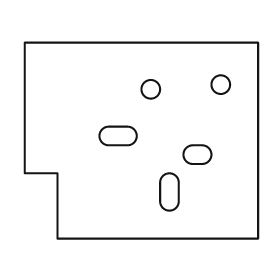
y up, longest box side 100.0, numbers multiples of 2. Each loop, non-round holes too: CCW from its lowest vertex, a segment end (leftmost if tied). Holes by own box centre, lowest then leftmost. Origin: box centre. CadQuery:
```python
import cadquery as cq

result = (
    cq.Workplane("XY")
    .moveTo(-36.0, -42.0)
    .lineTo(50.0, -42.0)
    .lineTo(50.0, 42.0)
    .lineTo(-50.0, 42.0)
    .lineTo(-50.0, -14.0)
    .lineTo(-36.0, -14.0)
    .close()
    .moveTo(8.0, -26.0)
    .threePointArc((12.0, -30.0), (16.0, -26.0))
    .lineTo(16.0, -18.0)
    .threePointArc((12.0, -14.0), (8.0, -18.0))
    .close()
    .moveTo(22.0, -10.0)
    .lineTo(26.0, -10.0)
    .threePointArc((30.0, -6.0), (26.0, -2.0))
    .lineTo(22.0, -2.0)
    .threePointArc((18.0, -6.0), (22.0, -10.0))
    .close()
    .moveTo(-14.0, -2.0)
    .lineTo(-6.0, -2.0)
    .threePointArc((-2.0, 2.0), (-6.0, 6.0))
    .lineTo(-14.0, 6.0)
    .threePointArc((-18.0, 2.0), (-14.0, -2.0))
    .close()
    .moveTo(4.0, 22.0)
    .circle(4.0)
    .moveTo(34.0, 24.0)
    .circle(4.0)
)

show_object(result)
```